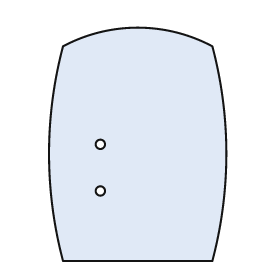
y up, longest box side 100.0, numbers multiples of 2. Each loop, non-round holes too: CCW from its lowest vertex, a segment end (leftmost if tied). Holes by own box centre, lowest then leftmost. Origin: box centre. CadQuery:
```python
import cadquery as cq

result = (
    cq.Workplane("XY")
    .moveTo(-32.0, -50.0)
    .lineTo(32.0, -50.0)
    .threePointArc((38.0, -4.0), (32.0, 42.0))
    .threePointArc((0.0, 50.0), (-32.0, 42.0))
    .threePointArc((-38.0, -4.0), (-32.0, -50.0))
    .close()
    .moveTo(-16.0, -20.0)
    .circle(2.0)
    .moveTo(-16.0, 0.0)
    .circle(2.0)
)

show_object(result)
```